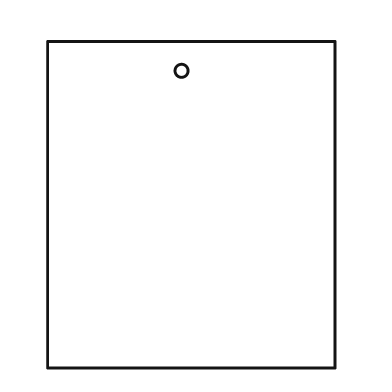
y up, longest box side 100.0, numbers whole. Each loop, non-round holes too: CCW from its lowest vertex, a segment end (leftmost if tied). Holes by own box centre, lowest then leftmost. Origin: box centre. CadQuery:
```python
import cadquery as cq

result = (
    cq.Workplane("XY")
    .moveTo(-44.0, -50.0)
    .lineTo(44.0, -50.0)
    .lineTo(44.0, 50.0)
    .lineTo(-44.0, 50.0)
    .close()
    .moveTo(-3.0, 41.0)
    .circle(2.0)
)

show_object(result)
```